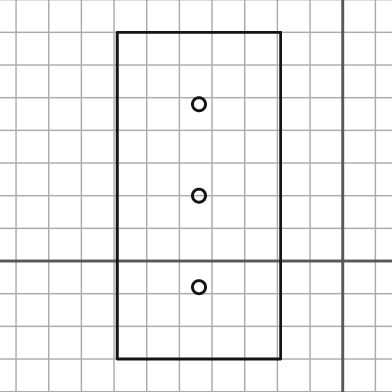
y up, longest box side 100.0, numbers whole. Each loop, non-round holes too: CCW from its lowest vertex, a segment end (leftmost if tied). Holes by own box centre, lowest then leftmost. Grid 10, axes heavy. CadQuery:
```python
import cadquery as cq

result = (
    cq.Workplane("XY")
    .moveTo(-69.0, -30.0)
    .lineTo(-19.0, -30.0)
    .lineTo(-19.0, 70.0)
    .lineTo(-69.0, 70.0)
    .close()
    .moveTo(-44.0, -8.0)
    .circle(2.0)
    .moveTo(-44.0, 20.0)
    .circle(2.0)
    .moveTo(-44.0, 48.0)
    .circle(2.0)
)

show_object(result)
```